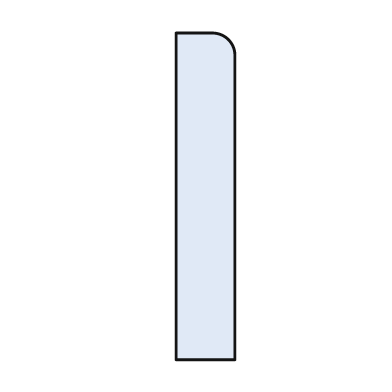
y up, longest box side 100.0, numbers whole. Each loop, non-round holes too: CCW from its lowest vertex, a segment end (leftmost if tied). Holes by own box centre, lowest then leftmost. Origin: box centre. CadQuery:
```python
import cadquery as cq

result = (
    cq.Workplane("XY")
    .moveTo(-9.0, -50.0)
    .lineTo(9.0, -50.0)
    .lineTo(9.0, 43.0)
    .threePointArc((7.0, 48.0), (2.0, 50.0))
    .lineTo(-9.0, 50.0)
    .close()
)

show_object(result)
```